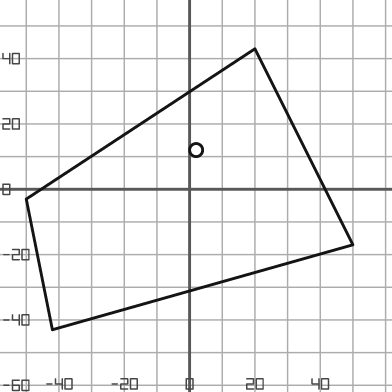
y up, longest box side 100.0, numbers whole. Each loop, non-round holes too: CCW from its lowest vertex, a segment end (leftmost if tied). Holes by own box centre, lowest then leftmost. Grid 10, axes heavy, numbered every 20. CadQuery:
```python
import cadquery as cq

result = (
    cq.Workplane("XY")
    .moveTo(-42.0, -43.0)
    .lineTo(50.0, -17.0)
    .lineTo(20.0, 43.0)
    .lineTo(-50.0, -3.0)
    .close()
    .moveTo(2.0, 12.0)
    .circle(2.0)
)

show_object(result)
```